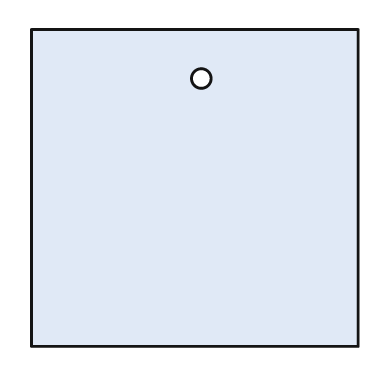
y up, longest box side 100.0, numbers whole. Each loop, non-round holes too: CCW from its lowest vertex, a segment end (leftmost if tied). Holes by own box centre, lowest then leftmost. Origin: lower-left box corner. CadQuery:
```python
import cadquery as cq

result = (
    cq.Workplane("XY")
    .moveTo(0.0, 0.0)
    .lineTo(100.0, 0.0)
    .lineTo(100.0, 97.0)
    .lineTo(0.0, 97.0)
    .close()
    .moveTo(52.0, 82.0)
    .circle(3.0)
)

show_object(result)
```